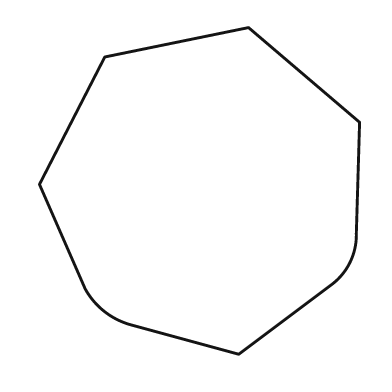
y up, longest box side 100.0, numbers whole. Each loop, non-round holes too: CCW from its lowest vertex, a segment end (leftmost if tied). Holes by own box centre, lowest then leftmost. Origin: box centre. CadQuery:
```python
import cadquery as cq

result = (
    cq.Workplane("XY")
    .moveTo(12.0, -50.0)
    .lineTo(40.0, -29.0)
    .threePointArc((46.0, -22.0), (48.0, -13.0))
    .lineTo(49.0, 21.0)
    .lineTo(15.0, 50.0)
    .lineTo(-29.0, 41.0)
    .lineTo(-49.0, 2.0)
    .lineTo(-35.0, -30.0)
    .threePointArc((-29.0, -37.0), (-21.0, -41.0))
    .close()
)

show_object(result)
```